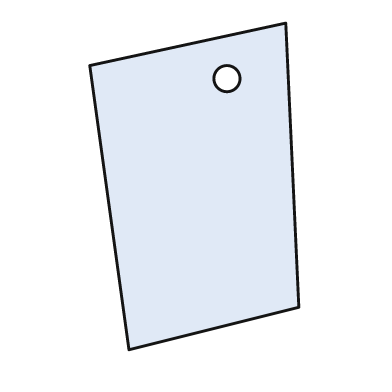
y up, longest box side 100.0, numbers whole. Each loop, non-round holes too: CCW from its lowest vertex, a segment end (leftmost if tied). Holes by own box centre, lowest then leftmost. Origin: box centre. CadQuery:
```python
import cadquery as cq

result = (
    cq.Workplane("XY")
    .moveTo(-20.0, -50.0)
    .lineTo(32.0, -37.0)
    .lineTo(28.0, 50.0)
    .lineTo(-32.0, 37.0)
    .close()
    .moveTo(10.0, 33.0)
    .circle(4.0)
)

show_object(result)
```